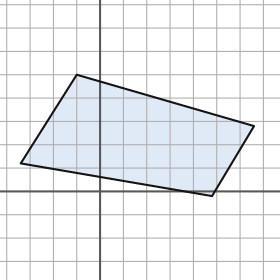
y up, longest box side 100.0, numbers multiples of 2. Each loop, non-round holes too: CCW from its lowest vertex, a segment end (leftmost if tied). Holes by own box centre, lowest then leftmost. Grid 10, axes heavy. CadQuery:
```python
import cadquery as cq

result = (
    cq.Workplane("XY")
    .moveTo(48.0, -2.0)
    .lineTo(66.0, 28.0)
    .lineTo(-10.0, 50.0)
    .lineTo(-34.0, 12.0)
    .close()
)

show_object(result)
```